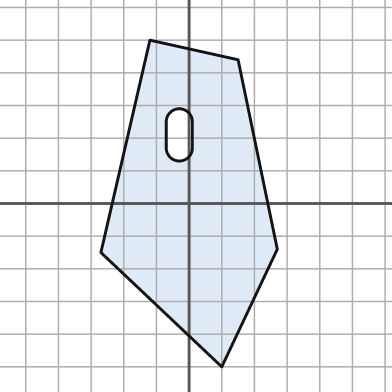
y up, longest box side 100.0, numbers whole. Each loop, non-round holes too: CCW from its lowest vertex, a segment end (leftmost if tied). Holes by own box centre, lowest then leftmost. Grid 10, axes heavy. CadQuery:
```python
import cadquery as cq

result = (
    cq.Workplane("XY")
    .moveTo(10.0, -50.0)
    .lineTo(27.0, -14.0)
    .lineTo(15.0, 44.0)
    .lineTo(-12.0, 50.0)
    .lineTo(-27.0, -15.0)
    .close()
    .moveTo(-7.0, 17.0)
    .threePointArc((-3.0, 13.0), (1.0, 17.0))
    .lineTo(1.0, 25.0)
    .threePointArc((-3.0, 29.0), (-7.0, 25.0))
    .close()
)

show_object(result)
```